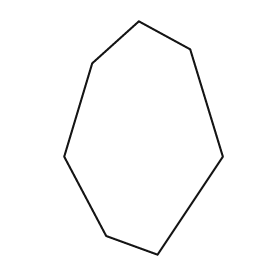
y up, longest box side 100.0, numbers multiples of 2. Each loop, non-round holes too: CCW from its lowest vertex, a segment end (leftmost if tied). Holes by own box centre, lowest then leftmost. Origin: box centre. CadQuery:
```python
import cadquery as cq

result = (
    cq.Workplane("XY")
    .moveTo(6.0, -50.0)
    .lineTo(34.0, -8.0)
    .lineTo(20.0, 38.0)
    .lineTo(-2.0, 50.0)
    .lineTo(-22.0, 32.0)
    .lineTo(-34.0, -8.0)
    .lineTo(-16.0, -42.0)
    .close()
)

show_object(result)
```